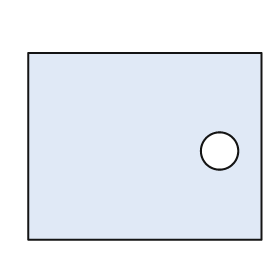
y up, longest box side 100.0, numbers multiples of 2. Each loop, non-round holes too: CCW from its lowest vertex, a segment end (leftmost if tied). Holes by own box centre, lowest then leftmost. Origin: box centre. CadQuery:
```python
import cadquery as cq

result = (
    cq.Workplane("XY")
    .moveTo(-50.0, -40.0)
    .lineTo(50.0, -40.0)
    .lineTo(50.0, 40.0)
    .lineTo(-50.0, 40.0)
    .close()
    .moveTo(32.0, -2.0)
    .circle(8.0)
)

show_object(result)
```